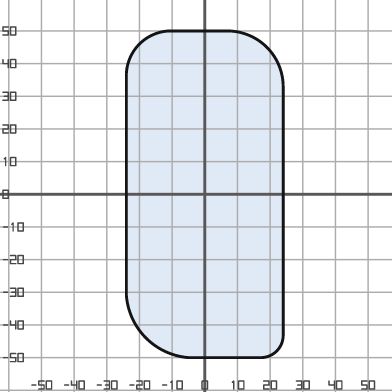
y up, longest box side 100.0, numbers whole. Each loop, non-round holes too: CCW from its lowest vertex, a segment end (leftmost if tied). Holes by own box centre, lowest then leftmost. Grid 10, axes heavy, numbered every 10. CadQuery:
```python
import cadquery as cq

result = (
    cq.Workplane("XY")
    .moveTo(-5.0, -50.0)
    .lineTo(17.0, -50.0)
    .threePointArc((22.0, -48.0), (24.0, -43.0))
    .lineTo(24.0, 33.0)
    .threePointArc((19.0, 45.0), (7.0, 50.0))
    .lineTo(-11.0, 50.0)
    .threePointArc((-20.0, 46.0), (-24.0, 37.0))
    .lineTo(-24.0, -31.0)
    .threePointArc((-18.0, -44.0), (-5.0, -50.0))
    .close()
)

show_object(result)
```